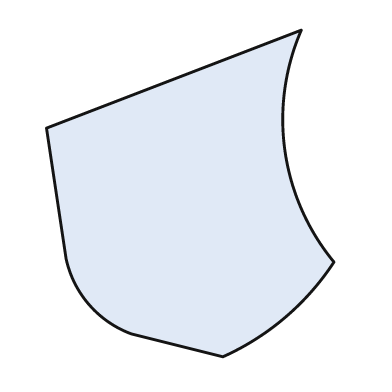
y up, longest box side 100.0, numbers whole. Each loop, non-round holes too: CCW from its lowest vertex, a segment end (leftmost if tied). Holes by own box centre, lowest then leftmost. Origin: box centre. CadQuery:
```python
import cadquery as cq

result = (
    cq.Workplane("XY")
    .moveTo(10.0, -50.0)
    .threePointArc((29.0, -38.0), (44.0, -21.0))
    .threePointArc((29.0, 13.0), (34.0, 50.0))
    .lineTo(-44.0, 20.0)
    .lineTo(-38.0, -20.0)
    .threePointArc((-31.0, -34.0), (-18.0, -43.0))
    .close()
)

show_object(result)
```